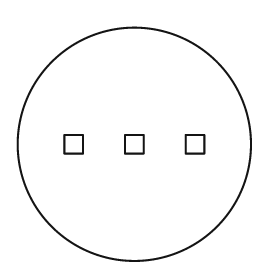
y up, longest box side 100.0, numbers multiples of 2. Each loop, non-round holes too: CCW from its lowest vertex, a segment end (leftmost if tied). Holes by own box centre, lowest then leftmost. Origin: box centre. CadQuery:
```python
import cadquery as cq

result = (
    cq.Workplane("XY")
    .moveTo(0.0, 0.0)
    .circle(50.0)
    .moveTo(-30.0, -4.0)
    .lineTo(-22.0, -4.0)
    .lineTo(-22.0, 4.0)
    .lineTo(-30.0, 4.0)
    .close()
    .moveTo(-4.0, -4.0)
    .lineTo(4.0, -4.0)
    .lineTo(4.0, 4.0)
    .lineTo(-4.0, 4.0)
    .close()
    .moveTo(22.0, -4.0)
    .lineTo(30.0, -4.0)
    .lineTo(30.0, 4.0)
    .lineTo(22.0, 4.0)
    .close()
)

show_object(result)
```